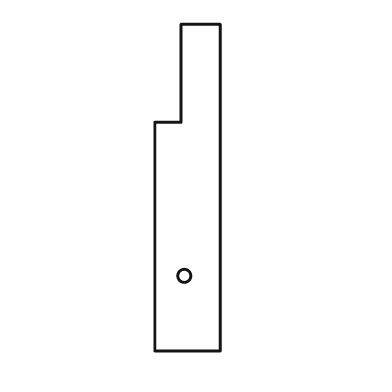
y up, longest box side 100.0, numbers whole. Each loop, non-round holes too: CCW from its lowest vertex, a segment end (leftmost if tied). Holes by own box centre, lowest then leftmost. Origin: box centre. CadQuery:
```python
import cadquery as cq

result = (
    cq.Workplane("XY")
    .moveTo(-10.0, -50.0)
    .lineTo(10.0, -50.0)
    .lineTo(10.0, 50.0)
    .lineTo(-2.0, 50.0)
    .lineTo(-2.0, 20.0)
    .lineTo(-10.0, 20.0)
    .close()
    .moveTo(-1.0, -27.0)
    .circle(2.0)
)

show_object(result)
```